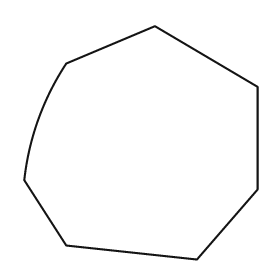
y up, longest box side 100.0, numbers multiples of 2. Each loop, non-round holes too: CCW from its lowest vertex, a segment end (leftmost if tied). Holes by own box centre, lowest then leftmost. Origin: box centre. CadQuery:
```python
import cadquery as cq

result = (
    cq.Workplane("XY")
    .moveTo(24.0, -50.0)
    .lineTo(50.0, -20.0)
    .lineTo(50.0, 24.0)
    .lineTo(6.0, 50.0)
    .lineTo(-32.0, 34.0)
    .threePointArc((-44.0, 10.0), (-50.0, -16.0))
    .lineTo(-32.0, -44.0)
    .close()
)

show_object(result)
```